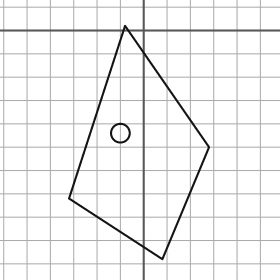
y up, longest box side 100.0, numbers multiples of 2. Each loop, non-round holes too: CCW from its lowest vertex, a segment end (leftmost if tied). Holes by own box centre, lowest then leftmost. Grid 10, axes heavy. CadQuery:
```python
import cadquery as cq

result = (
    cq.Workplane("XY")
    .moveTo(8.0, -98.0)
    .lineTo(28.0, -50.0)
    .lineTo(-8.0, 2.0)
    .lineTo(-32.0, -72.0)
    .close()
    .moveTo(-10.0, -44.0)
    .circle(4.0)
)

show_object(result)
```